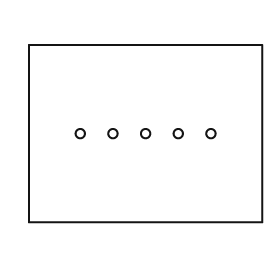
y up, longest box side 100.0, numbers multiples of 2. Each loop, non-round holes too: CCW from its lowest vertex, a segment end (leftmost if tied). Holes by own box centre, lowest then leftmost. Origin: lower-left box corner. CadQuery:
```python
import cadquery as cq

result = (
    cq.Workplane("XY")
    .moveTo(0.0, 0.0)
    .lineTo(100.0, 0.0)
    .lineTo(100.0, 76.0)
    .lineTo(0.0, 76.0)
    .close()
    .moveTo(22.0, 38.0)
    .circle(2.0)
    .moveTo(36.0, 38.0)
    .circle(2.0)
    .moveTo(50.0, 38.0)
    .circle(2.0)
    .moveTo(64.0, 38.0)
    .circle(2.0)
    .moveTo(78.0, 38.0)
    .circle(2.0)
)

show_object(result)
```